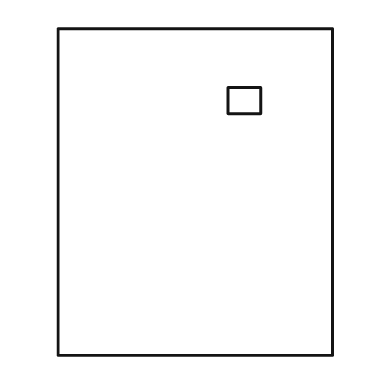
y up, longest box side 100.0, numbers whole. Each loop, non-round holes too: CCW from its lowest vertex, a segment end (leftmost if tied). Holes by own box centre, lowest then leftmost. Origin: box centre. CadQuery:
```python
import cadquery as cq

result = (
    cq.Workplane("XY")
    .moveTo(-42.0, -50.0)
    .lineTo(42.0, -50.0)
    .lineTo(42.0, 50.0)
    .lineTo(-42.0, 50.0)
    .close()
    .moveTo(10.0, 24.0)
    .lineTo(20.0, 24.0)
    .lineTo(20.0, 32.0)
    .lineTo(10.0, 32.0)
    .close()
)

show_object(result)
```